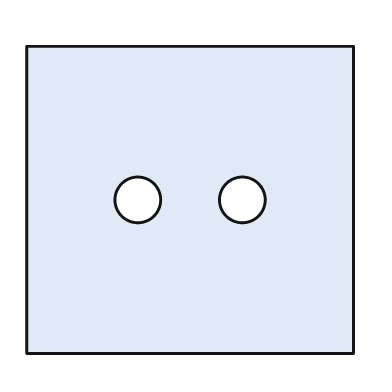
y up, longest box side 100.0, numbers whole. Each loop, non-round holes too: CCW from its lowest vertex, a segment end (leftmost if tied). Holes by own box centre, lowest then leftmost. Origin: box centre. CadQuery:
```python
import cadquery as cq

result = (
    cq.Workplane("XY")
    .moveTo(-50.0, -47.0)
    .lineTo(50.0, -47.0)
    .lineTo(50.0, 47.0)
    .lineTo(-50.0, 47.0)
    .close()
    .moveTo(-16.0, 0.0)
    .circle(7.0)
    .moveTo(16.0, 0.0)
    .circle(7.0)
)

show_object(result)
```